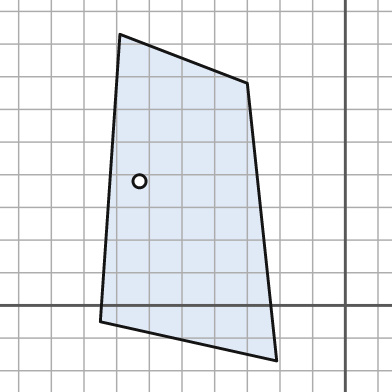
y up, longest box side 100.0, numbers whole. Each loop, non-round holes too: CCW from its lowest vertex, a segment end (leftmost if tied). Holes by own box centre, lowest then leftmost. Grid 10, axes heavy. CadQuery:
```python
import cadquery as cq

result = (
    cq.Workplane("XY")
    .moveTo(-21.0, -17.0)
    .lineTo(-30.0, 68.0)
    .lineTo(-69.0, 83.0)
    .lineTo(-75.0, -5.0)
    .close()
    .moveTo(-63.0, 38.0)
    .circle(2.0)
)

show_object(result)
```